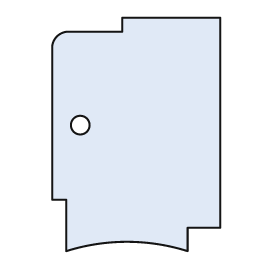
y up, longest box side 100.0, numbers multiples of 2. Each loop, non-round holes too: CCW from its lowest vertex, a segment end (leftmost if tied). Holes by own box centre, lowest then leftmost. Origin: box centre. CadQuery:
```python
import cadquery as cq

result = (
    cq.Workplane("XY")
    .moveTo(-30.0, -50.0)
    .threePointArc((-4.0, -46.0), (22.0, -50.0))
    .lineTo(22.0, -40.0)
    .lineTo(36.0, -40.0)
    .lineTo(36.0, 50.0)
    .lineTo(-6.0, 50.0)
    .lineTo(-6.0, 44.0)
    .lineTo(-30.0, 44.0)
    .threePointArc((-34.0, 42.0), (-36.0, 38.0))
    .lineTo(-36.0, -28.0)
    .lineTo(-30.0, -28.0)
    .close()
    .moveTo(-24.0, 4.0)
    .circle(4.0)
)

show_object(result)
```